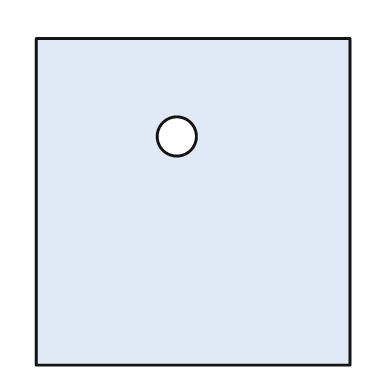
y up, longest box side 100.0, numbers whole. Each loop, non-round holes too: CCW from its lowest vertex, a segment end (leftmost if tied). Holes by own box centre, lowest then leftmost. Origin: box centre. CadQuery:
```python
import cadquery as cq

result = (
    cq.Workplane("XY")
    .moveTo(-48.0, -50.0)
    .lineTo(48.0, -50.0)
    .lineTo(48.0, 50.0)
    .lineTo(-48.0, 50.0)
    .close()
    .moveTo(-5.0, 20.0)
    .circle(6.0)
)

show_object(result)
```